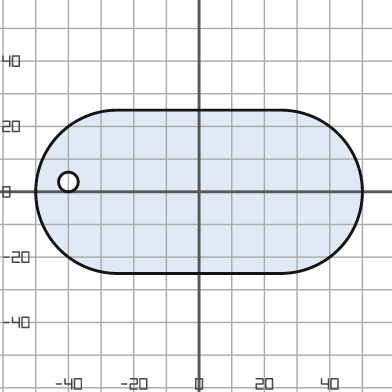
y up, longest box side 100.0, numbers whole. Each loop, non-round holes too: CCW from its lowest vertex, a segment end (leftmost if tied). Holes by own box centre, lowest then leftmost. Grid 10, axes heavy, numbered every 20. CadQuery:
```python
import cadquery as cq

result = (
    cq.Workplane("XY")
    .moveTo(-25.0, -25.0)
    .lineTo(25.0, -25.0)
    .threePointArc((50.0, 0.0), (25.0, 25.0))
    .lineTo(-25.0, 25.0)
    .threePointArc((-50.0, 0.0), (-25.0, -25.0))
    .close()
    .moveTo(-40.0, 3.0)
    .circle(3.0)
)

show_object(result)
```